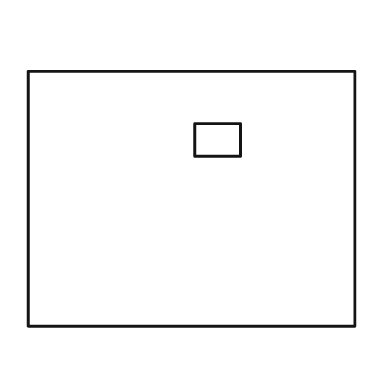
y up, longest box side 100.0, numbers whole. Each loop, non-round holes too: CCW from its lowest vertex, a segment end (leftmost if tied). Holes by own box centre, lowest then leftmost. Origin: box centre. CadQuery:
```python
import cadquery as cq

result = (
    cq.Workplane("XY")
    .moveTo(-50.0, -39.0)
    .lineTo(50.0, -39.0)
    .lineTo(50.0, 39.0)
    .lineTo(-50.0, 39.0)
    .close()
    .moveTo(1.0, 13.0)
    .lineTo(15.0, 13.0)
    .lineTo(15.0, 23.0)
    .lineTo(1.0, 23.0)
    .close()
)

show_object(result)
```